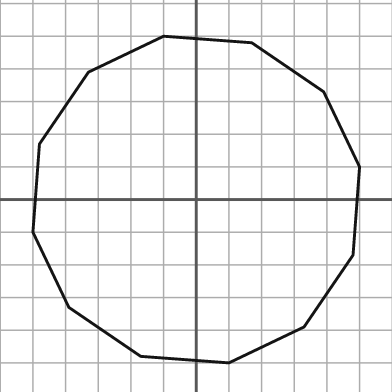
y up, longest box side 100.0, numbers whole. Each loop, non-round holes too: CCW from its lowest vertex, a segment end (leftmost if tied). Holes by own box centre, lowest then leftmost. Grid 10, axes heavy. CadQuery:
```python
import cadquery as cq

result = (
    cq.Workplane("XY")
    .moveTo(10.0, -50.0)
    .lineTo(33.0, -39.0)
    .lineTo(48.0, -17.0)
    .lineTo(50.0, 10.0)
    .lineTo(39.0, 33.0)
    .lineTo(17.0, 48.0)
    .lineTo(-10.0, 50.0)
    .lineTo(-33.0, 39.0)
    .lineTo(-48.0, 17.0)
    .lineTo(-50.0, -10.0)
    .lineTo(-39.0, -33.0)
    .lineTo(-17.0, -48.0)
    .close()
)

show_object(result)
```